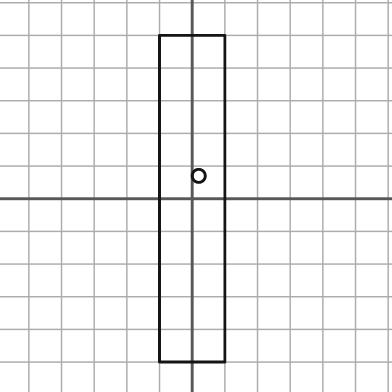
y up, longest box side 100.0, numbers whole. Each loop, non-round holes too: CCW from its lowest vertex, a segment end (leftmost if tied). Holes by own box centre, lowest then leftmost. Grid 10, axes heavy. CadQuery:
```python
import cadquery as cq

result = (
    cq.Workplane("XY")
    .moveTo(-10.0, -50.0)
    .lineTo(10.0, -50.0)
    .lineTo(10.0, 50.0)
    .lineTo(-10.0, 50.0)
    .close()
    .moveTo(2.0, 7.0)
    .circle(2.0)
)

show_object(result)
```